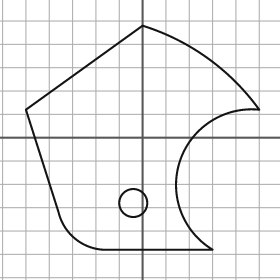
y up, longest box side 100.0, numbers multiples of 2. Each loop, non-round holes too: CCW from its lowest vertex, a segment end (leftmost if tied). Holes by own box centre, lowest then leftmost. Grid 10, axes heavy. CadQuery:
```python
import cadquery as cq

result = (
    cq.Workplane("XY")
    .moveTo(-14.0, -48.0)
    .lineTo(30.0, -48.0)
    .threePointArc((16.0, -10.0), (50.0, 12.0))
    .threePointArc((28.0, 34.0), (0.0, 48.0))
    .lineTo(-50.0, 12.0)
    .lineTo(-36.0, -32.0)
    .threePointArc((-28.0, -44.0), (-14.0, -48.0))
    .close()
    .moveTo(-4.0, -28.0)
    .circle(6.0)
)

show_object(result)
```